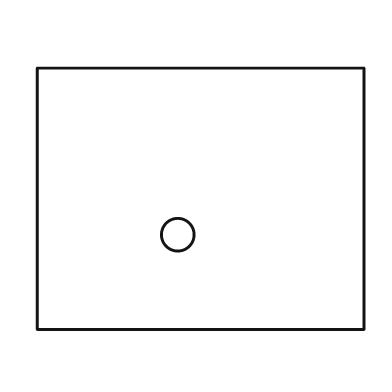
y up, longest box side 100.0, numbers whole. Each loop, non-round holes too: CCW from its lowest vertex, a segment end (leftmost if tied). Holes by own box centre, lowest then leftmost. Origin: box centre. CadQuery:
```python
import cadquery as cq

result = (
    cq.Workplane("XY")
    .moveTo(-50.0, -40.0)
    .lineTo(50.0, -40.0)
    .lineTo(50.0, 40.0)
    .lineTo(-50.0, 40.0)
    .close()
    .moveTo(-7.0, -11.0)
    .circle(5.0)
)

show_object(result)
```